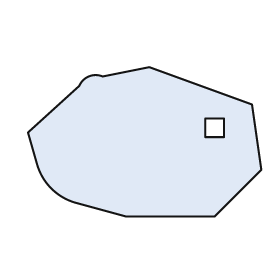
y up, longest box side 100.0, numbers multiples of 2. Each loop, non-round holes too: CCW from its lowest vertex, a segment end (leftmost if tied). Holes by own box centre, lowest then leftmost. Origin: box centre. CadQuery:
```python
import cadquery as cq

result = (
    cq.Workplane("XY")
    .moveTo(-8.0, -32.0)
    .lineTo(30.0, -32.0)
    .lineTo(50.0, -12.0)
    .lineTo(46.0, 16.0)
    .lineTo(2.0, 32.0)
    .lineTo(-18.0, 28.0)
    .threePointArc((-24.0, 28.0), (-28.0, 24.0))
    .lineTo(-50.0, 4.0)
    .lineTo(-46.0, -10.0)
    .threePointArc((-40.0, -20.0), (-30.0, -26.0))
    .close()
    .moveTo(26.0, 2.0)
    .lineTo(34.0, 2.0)
    .lineTo(34.0, 10.0)
    .lineTo(26.0, 10.0)
    .close()
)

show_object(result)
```